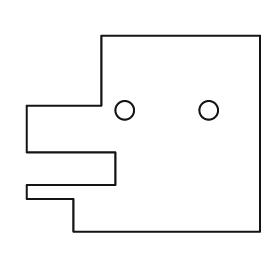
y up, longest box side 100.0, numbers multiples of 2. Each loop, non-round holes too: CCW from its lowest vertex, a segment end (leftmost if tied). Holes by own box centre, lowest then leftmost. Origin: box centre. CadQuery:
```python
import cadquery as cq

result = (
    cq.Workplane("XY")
    .moveTo(-30.0, -42.0)
    .lineTo(50.0, -42.0)
    .lineTo(50.0, 42.0)
    .lineTo(-18.0, 42.0)
    .lineTo(-18.0, 12.0)
    .lineTo(-50.0, 12.0)
    .lineTo(-50.0, -8.0)
    .lineTo(-12.0, -8.0)
    .lineTo(-12.0, -22.0)
    .lineTo(-50.0, -22.0)
    .lineTo(-50.0, -28.0)
    .lineTo(-30.0, -28.0)
    .close()
    .moveTo(-8.0, 10.0)
    .circle(4.0)
    .moveTo(28.0, 10.0)
    .circle(4.0)
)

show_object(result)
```